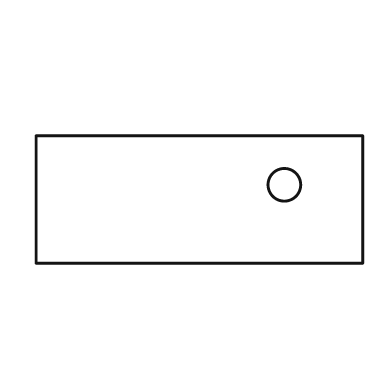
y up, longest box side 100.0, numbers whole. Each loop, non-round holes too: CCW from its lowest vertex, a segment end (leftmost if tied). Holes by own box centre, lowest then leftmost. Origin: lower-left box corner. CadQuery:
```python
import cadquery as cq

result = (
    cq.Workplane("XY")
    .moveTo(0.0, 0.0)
    .lineTo(100.0, 0.0)
    .lineTo(100.0, 39.0)
    .lineTo(0.0, 39.0)
    .close()
    .moveTo(76.0, 24.0)
    .circle(5.0)
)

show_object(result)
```